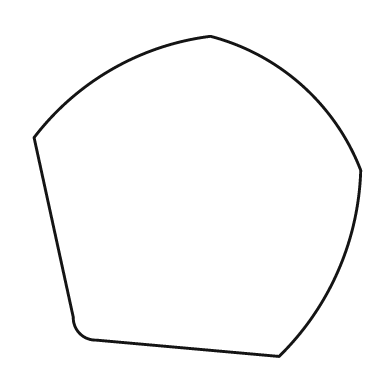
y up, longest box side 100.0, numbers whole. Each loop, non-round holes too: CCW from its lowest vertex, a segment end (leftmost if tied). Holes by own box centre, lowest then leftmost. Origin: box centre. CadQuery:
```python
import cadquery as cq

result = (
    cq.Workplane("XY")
    .moveTo(25.0, -49.0)
    .threePointArc((43.0, -23.0), (50.0, 8.0))
    .threePointArc((32.0, 34.0), (4.0, 49.0))
    .threePointArc((-26.0, 39.0), (-50.0, 18.0))
    .lineTo(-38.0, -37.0)
    .threePointArc((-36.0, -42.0), (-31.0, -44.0))
    .close()
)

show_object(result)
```